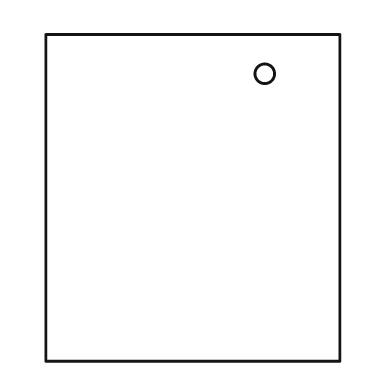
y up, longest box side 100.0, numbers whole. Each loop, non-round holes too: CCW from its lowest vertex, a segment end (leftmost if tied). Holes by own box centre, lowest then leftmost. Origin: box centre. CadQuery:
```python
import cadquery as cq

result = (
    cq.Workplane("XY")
    .moveTo(-45.0, -50.0)
    .lineTo(45.0, -50.0)
    .lineTo(45.0, 50.0)
    .lineTo(-45.0, 50.0)
    .close()
    .moveTo(22.0, 38.0)
    .circle(3.0)
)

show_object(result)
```